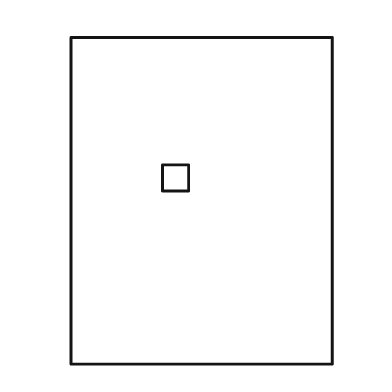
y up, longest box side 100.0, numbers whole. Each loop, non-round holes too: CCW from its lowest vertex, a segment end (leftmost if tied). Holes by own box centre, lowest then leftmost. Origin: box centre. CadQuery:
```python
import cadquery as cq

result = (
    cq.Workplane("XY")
    .moveTo(-40.0, -50.0)
    .lineTo(40.0, -50.0)
    .lineTo(40.0, 50.0)
    .lineTo(-40.0, 50.0)
    .close()
    .moveTo(-12.0, 3.0)
    .lineTo(-4.0, 3.0)
    .lineTo(-4.0, 11.0)
    .lineTo(-12.0, 11.0)
    .close()
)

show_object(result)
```